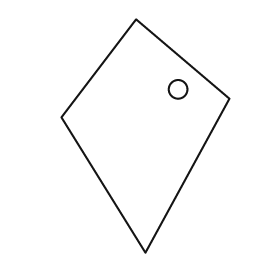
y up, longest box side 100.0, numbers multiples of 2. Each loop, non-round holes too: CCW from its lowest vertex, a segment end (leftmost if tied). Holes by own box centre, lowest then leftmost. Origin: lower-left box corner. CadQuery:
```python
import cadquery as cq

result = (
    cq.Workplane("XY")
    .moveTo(36.0, 0.0)
    .lineTo(72.0, 66.0)
    .lineTo(32.0, 100.0)
    .lineTo(0.0, 58.0)
    .close()
    .moveTo(50.0, 70.0)
    .circle(4.0)
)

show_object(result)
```